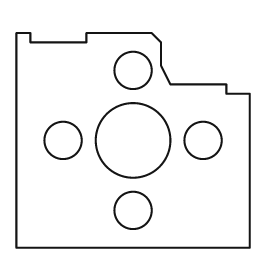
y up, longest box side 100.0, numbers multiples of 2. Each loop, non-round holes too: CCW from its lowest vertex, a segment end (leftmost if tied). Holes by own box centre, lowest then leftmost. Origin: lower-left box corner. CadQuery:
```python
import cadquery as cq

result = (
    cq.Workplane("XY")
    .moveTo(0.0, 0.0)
    .lineTo(100.0, 0.0)
    .lineTo(100.0, 66.0)
    .lineTo(90.0, 66.0)
    .lineTo(90.0, 70.0)
    .lineTo(66.0, 70.0)
    .lineTo(62.0, 78.0)
    .lineTo(62.0, 88.0)
    .lineTo(58.0, 92.0)
    .lineTo(30.0, 92.0)
    .lineTo(30.0, 88.0)
    .lineTo(6.0, 88.0)
    .lineTo(6.0, 92.0)
    .lineTo(0.0, 92.0)
    .close()
    .moveTo(50.0, 16.0)
    .circle(8.0)
    .moveTo(20.0, 46.0)
    .circle(8.0)
    .moveTo(50.0, 46.0)
    .circle(16.0)
    .moveTo(80.0, 46.0)
    .circle(8.0)
    .moveTo(50.0, 76.0)
    .circle(8.0)
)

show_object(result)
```